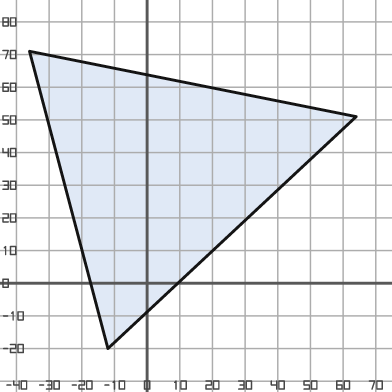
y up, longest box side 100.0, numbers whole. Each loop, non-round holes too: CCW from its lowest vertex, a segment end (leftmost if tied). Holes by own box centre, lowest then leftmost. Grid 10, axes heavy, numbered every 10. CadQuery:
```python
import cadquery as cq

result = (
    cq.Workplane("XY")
    .moveTo(-12.0, -20.0)
    .lineTo(64.0, 51.0)
    .lineTo(-36.0, 71.0)
    .close()
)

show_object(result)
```